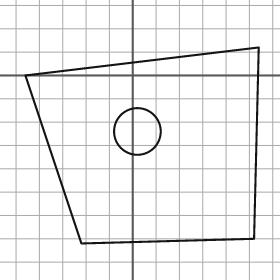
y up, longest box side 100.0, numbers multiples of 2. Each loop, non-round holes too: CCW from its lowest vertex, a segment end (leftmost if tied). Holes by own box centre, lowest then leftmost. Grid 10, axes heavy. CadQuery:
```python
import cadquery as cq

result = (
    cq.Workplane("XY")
    .moveTo(-22.0, -72.0)
    .lineTo(52.0, -70.0)
    .lineTo(54.0, 12.0)
    .lineTo(-46.0, 0.0)
    .close()
    .moveTo(2.0, -24.0)
    .circle(10.0)
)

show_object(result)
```